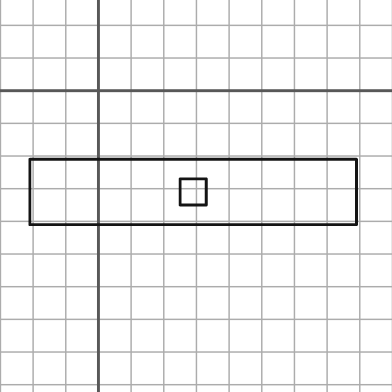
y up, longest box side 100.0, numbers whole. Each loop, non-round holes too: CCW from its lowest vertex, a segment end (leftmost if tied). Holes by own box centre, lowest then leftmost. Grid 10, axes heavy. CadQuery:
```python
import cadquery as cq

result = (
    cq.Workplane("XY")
    .moveTo(-21.0, -41.0)
    .lineTo(79.0, -41.0)
    .lineTo(79.0, -21.0)
    .lineTo(-21.0, -21.0)
    .close()
    .moveTo(25.0, -35.0)
    .lineTo(33.0, -35.0)
    .lineTo(33.0, -27.0)
    .lineTo(25.0, -27.0)
    .close()
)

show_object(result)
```